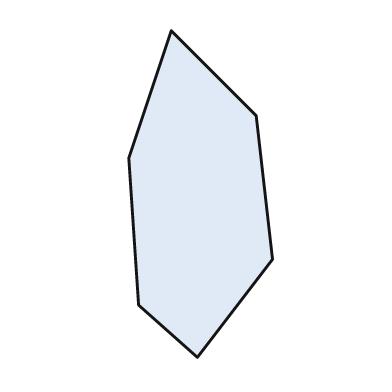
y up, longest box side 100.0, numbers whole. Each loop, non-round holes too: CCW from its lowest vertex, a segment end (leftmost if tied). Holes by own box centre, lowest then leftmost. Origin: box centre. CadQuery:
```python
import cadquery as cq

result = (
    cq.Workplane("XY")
    .moveTo(-1.0, -50.0)
    .lineTo(22.0, -20.0)
    .lineTo(17.0, 24.0)
    .lineTo(-9.0, 50.0)
    .lineTo(-22.0, 11.0)
    .lineTo(-19.0, -34.0)
    .close()
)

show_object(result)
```